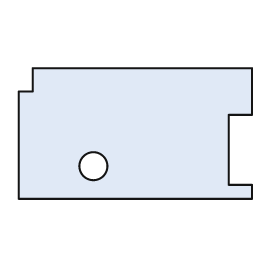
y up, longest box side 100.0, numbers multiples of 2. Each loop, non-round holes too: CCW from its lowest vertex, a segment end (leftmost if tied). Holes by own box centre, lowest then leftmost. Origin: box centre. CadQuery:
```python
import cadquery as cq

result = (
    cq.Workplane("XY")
    .moveTo(-50.0, -28.0)
    .lineTo(50.0, -28.0)
    .lineTo(50.0, -22.0)
    .lineTo(40.0, -22.0)
    .lineTo(40.0, 8.0)
    .lineTo(50.0, 8.0)
    .lineTo(50.0, 28.0)
    .lineTo(-44.0, 28.0)
    .lineTo(-44.0, 18.0)
    .lineTo(-50.0, 18.0)
    .close()
    .moveTo(-18.0, -14.0)
    .circle(6.0)
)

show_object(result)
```